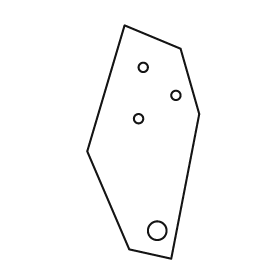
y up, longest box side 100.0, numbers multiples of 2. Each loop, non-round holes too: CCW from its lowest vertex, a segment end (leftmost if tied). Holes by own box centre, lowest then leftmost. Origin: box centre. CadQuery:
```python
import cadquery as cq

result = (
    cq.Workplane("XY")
    .moveTo(12.0, -50.0)
    .lineTo(24.0, 12.0)
    .lineTo(16.0, 40.0)
    .lineTo(-8.0, 50.0)
    .lineTo(-24.0, -4.0)
    .lineTo(-6.0, -46.0)
    .close()
    .moveTo(6.0, -38.0)
    .circle(4.0)
    .moveTo(-2.0, 10.0)
    .circle(2.0)
    .moveTo(14.0, 20.0)
    .circle(2.0)
    .moveTo(0.0, 32.0)
    .circle(2.0)
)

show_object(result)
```